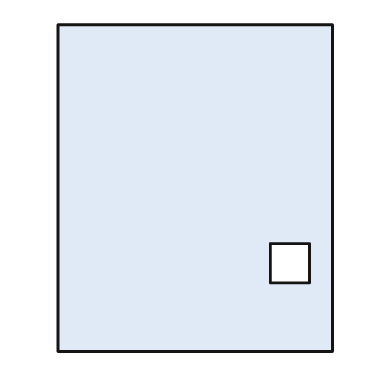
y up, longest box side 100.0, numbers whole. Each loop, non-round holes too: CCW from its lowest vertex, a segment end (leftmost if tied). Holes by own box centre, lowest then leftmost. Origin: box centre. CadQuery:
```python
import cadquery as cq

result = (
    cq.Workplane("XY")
    .moveTo(-42.0, -50.0)
    .lineTo(42.0, -50.0)
    .lineTo(42.0, 50.0)
    .lineTo(-42.0, 50.0)
    .close()
    .moveTo(23.0, -29.0)
    .lineTo(35.0, -29.0)
    .lineTo(35.0, -17.0)
    .lineTo(23.0, -17.0)
    .close()
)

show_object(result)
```